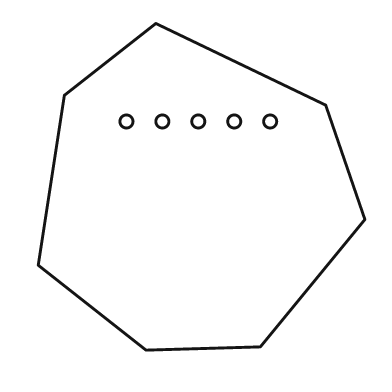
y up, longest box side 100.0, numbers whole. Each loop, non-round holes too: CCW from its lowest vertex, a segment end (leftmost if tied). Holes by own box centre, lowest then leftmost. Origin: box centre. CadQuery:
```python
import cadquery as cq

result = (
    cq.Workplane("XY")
    .moveTo(-17.0, -50.0)
    .lineTo(18.0, -49.0)
    .lineTo(50.0, -10.0)
    .lineTo(38.0, 25.0)
    .lineTo(-14.0, 50.0)
    .lineTo(-42.0, 28.0)
    .lineTo(-50.0, -24.0)
    .close()
    .moveTo(-23.0, 20.0)
    .circle(2.0)
    .moveTo(-12.0, 20.0)
    .circle(2.0)
    .moveTo(-1.0, 20.0)
    .circle(2.0)
    .moveTo(10.0, 20.0)
    .circle(2.0)
    .moveTo(21.0, 20.0)
    .circle(2.0)
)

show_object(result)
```